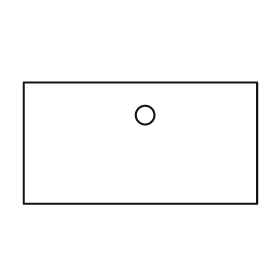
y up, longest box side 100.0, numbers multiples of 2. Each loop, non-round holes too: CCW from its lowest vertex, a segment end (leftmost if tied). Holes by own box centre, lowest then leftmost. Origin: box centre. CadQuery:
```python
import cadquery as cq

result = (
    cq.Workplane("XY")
    .moveTo(-50.0, -26.0)
    .lineTo(50.0, -26.0)
    .lineTo(50.0, 26.0)
    .lineTo(-50.0, 26.0)
    .close()
    .moveTo(2.0, 12.0)
    .circle(4.0)
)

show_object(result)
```